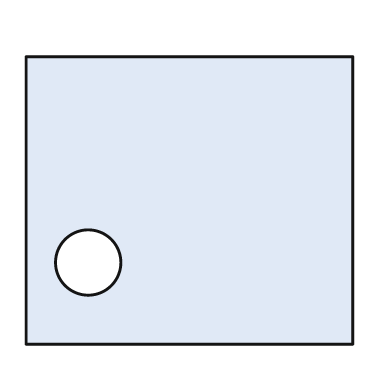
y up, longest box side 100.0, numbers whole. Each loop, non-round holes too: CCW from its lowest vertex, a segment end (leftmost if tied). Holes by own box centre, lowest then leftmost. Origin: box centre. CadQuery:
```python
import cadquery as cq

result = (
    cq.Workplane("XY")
    .moveTo(-50.0, -44.0)
    .lineTo(50.0, -44.0)
    .lineTo(50.0, 44.0)
    .lineTo(-50.0, 44.0)
    .close()
    .moveTo(-31.0, -19.0)
    .circle(10.0)
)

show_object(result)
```